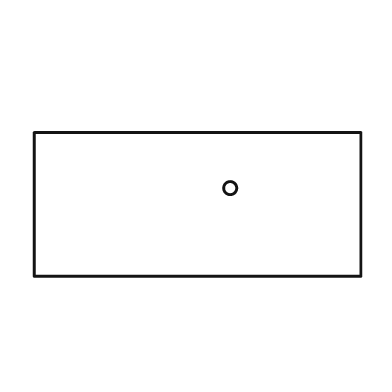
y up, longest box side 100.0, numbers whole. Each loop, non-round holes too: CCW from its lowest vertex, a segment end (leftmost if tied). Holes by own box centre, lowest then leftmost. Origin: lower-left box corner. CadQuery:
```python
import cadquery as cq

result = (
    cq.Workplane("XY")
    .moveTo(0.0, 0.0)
    .lineTo(100.0, 0.0)
    .lineTo(100.0, 44.0)
    .lineTo(0.0, 44.0)
    .close()
    .moveTo(60.0, 27.0)
    .circle(2.0)
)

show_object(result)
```